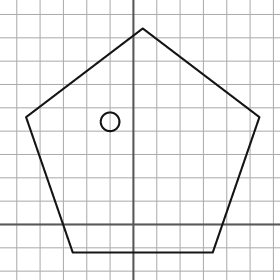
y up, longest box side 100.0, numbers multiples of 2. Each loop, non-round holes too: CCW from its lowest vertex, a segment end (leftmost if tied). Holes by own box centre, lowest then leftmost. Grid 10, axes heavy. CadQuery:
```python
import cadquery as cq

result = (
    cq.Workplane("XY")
    .moveTo(-26.0, -12.0)
    .lineTo(34.0, -12.0)
    .lineTo(54.0, 46.0)
    .lineTo(4.0, 84.0)
    .lineTo(-46.0, 46.0)
    .close()
    .moveTo(-10.0, 44.0)
    .circle(4.0)
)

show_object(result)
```